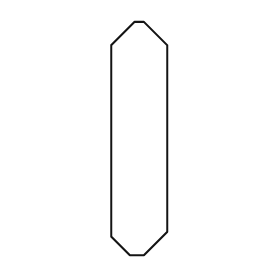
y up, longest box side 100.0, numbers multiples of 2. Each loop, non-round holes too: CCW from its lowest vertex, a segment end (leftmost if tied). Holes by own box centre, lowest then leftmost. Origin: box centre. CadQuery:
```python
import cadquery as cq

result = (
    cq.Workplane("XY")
    .moveTo(-4.0, -50.0)
    .lineTo(2.0, -50.0)
    .lineTo(12.0, -40.0)
    .lineTo(12.0, 40.0)
    .lineTo(2.0, 50.0)
    .lineTo(-2.0, 50.0)
    .lineTo(-12.0, 40.0)
    .lineTo(-12.0, -42.0)
    .close()
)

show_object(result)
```